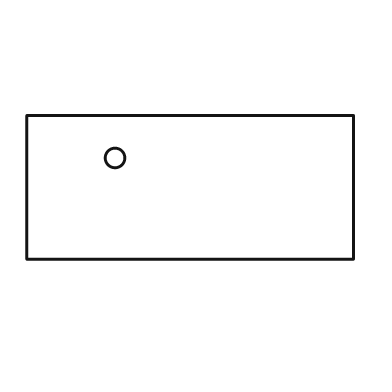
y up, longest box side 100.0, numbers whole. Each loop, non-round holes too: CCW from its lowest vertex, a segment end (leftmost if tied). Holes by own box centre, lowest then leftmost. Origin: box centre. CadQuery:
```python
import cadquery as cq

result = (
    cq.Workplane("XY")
    .moveTo(-50.0, -22.0)
    .lineTo(50.0, -22.0)
    .lineTo(50.0, 22.0)
    .lineTo(-50.0, 22.0)
    .close()
    .moveTo(-23.0, 9.0)
    .circle(3.0)
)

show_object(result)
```